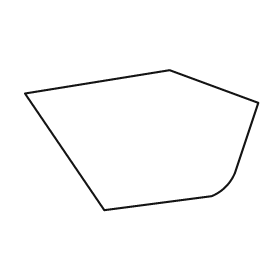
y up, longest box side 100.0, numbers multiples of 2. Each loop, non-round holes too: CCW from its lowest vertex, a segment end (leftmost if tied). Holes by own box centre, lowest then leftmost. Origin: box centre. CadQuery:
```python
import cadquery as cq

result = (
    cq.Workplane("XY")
    .moveTo(-16.0, -30.0)
    .lineTo(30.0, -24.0)
    .threePointArc((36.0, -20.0), (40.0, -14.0))
    .lineTo(50.0, 16.0)
    .lineTo(12.0, 30.0)
    .lineTo(-50.0, 20.0)
    .close()
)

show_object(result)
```